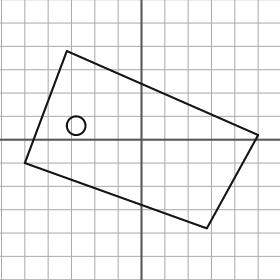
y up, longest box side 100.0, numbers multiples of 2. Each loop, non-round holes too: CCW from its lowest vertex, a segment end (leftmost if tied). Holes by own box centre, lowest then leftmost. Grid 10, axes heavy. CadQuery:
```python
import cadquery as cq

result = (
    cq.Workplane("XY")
    .moveTo(28.0, -38.0)
    .lineTo(50.0, 2.0)
    .lineTo(-32.0, 38.0)
    .lineTo(-50.0, -10.0)
    .close()
    .moveTo(-28.0, 6.0)
    .circle(4.0)
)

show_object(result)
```